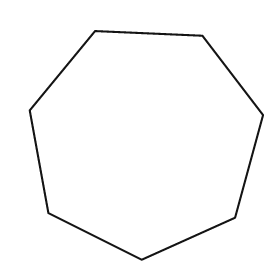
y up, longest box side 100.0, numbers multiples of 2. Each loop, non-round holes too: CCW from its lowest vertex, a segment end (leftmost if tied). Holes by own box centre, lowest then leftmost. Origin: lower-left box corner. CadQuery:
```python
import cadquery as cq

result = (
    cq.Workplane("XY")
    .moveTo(48.0, 0.0)
    .lineTo(88.0, 18.0)
    .lineTo(100.0, 62.0)
    .lineTo(74.0, 96.0)
    .lineTo(28.0, 98.0)
    .lineTo(0.0, 64.0)
    .lineTo(8.0, 20.0)
    .close()
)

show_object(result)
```